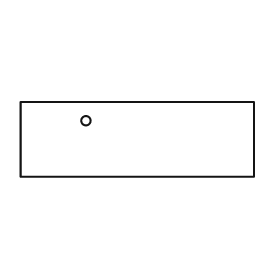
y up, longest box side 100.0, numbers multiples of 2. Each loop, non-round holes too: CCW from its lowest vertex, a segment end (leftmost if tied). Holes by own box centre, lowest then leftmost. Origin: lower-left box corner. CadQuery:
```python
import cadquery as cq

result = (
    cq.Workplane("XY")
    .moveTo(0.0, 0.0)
    .lineTo(100.0, 0.0)
    .lineTo(100.0, 32.0)
    .lineTo(0.0, 32.0)
    .close()
    .moveTo(28.0, 24.0)
    .circle(2.0)
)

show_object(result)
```